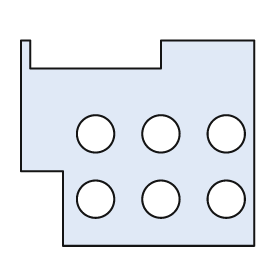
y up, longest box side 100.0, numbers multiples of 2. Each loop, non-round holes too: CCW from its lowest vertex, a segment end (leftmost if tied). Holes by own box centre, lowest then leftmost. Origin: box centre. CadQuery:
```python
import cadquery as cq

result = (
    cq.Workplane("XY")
    .moveTo(-32.0, -44.0)
    .lineTo(50.0, -44.0)
    .lineTo(50.0, 44.0)
    .lineTo(10.0, 44.0)
    .lineTo(10.0, 32.0)
    .lineTo(-46.0, 32.0)
    .lineTo(-46.0, 44.0)
    .lineTo(-50.0, 44.0)
    .lineTo(-50.0, -12.0)
    .lineTo(-32.0, -12.0)
    .close()
    .moveTo(-18.0, -24.0)
    .circle(8.0)
    .moveTo(10.0, -24.0)
    .circle(8.0)
    .moveTo(38.0, -24.0)
    .circle(8.0)
    .moveTo(-18.0, 4.0)
    .circle(8.0)
    .moveTo(10.0, 4.0)
    .circle(8.0)
    .moveTo(38.0, 4.0)
    .circle(8.0)
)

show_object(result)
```